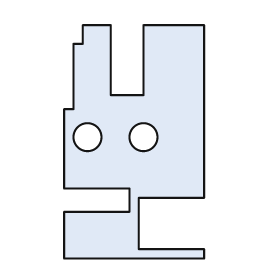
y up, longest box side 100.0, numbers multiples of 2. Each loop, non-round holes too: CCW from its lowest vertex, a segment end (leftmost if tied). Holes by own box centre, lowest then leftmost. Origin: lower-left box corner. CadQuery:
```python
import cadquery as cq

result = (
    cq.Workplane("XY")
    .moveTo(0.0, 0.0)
    .lineTo(60.0, 0.0)
    .lineTo(60.0, 4.0)
    .lineTo(32.0, 4.0)
    .lineTo(32.0, 26.0)
    .lineTo(60.0, 26.0)
    .lineTo(60.0, 100.0)
    .lineTo(34.0, 100.0)
    .lineTo(34.0, 70.0)
    .lineTo(20.0, 70.0)
    .lineTo(20.0, 100.0)
    .lineTo(8.0, 100.0)
    .lineTo(8.0, 92.0)
    .lineTo(4.0, 92.0)
    .lineTo(4.0, 64.0)
    .lineTo(0.0, 64.0)
    .lineTo(0.0, 30.0)
    .lineTo(28.0, 30.0)
    .lineTo(28.0, 20.0)
    .lineTo(0.0, 20.0)
    .close()
    .moveTo(10.0, 52.0)
    .circle(6.0)
    .moveTo(34.0, 52.0)
    .circle(6.0)
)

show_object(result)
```